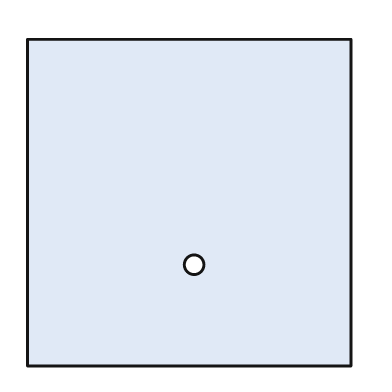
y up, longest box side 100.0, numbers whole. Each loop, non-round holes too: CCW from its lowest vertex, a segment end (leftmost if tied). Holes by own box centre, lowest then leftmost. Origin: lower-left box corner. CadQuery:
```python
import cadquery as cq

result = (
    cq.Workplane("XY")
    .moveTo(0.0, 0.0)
    .lineTo(99.0, 0.0)
    .lineTo(99.0, 100.0)
    .lineTo(0.0, 100.0)
    .close()
    .moveTo(51.0, 31.0)
    .circle(3.0)
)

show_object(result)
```